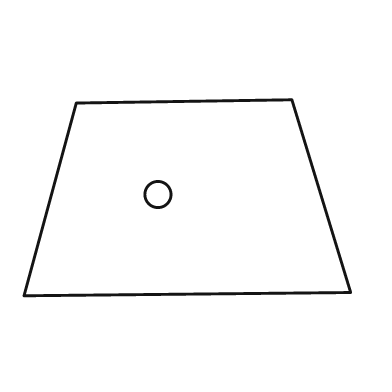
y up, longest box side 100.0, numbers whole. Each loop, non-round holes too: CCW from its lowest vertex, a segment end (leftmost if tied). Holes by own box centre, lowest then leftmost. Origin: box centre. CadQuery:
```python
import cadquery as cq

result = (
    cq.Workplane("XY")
    .moveTo(-50.0, -30.0)
    .lineTo(50.0, -29.0)
    .lineTo(32.0, 30.0)
    .lineTo(-34.0, 29.0)
    .close()
    .moveTo(-9.0, 1.0)
    .circle(4.0)
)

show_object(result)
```